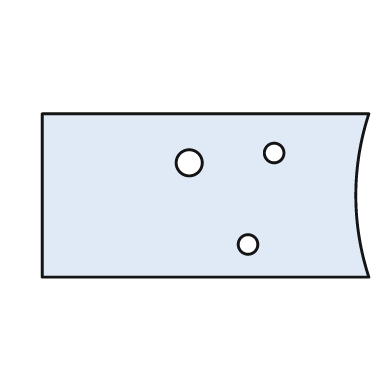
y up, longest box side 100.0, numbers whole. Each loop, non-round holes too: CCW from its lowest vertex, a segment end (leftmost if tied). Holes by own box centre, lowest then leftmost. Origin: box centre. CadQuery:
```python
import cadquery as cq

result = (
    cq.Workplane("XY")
    .moveTo(-50.0, -25.0)
    .lineTo(50.0, -25.0)
    .threePointArc((46.0, 0.0), (50.0, 25.0))
    .lineTo(-50.0, 25.0)
    .close()
    .moveTo(13.0, -15.0)
    .circle(3.0)
    .moveTo(-5.0, 10.0)
    .circle(4.0)
    .moveTo(21.0, 13.0)
    .circle(3.0)
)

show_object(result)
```